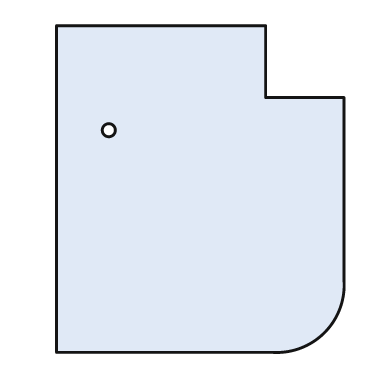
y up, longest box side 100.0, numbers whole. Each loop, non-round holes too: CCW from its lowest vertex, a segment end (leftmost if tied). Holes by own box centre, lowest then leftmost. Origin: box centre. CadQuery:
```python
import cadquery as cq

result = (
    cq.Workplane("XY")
    .moveTo(-44.0, -50.0)
    .lineTo(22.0, -50.0)
    .threePointArc((38.0, -44.0), (44.0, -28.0))
    .lineTo(44.0, 28.0)
    .lineTo(20.0, 28.0)
    .lineTo(20.0, 50.0)
    .lineTo(-44.0, 50.0)
    .close()
    .moveTo(-28.0, 18.0)
    .circle(2.0)
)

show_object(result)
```